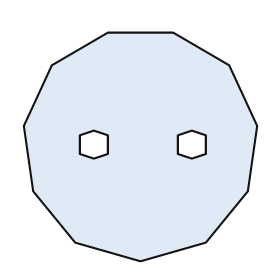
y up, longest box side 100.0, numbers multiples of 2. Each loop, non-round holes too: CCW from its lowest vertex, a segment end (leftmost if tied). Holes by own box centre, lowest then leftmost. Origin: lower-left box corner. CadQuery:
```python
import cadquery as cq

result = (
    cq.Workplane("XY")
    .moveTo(50.0, 0.0)
    .lineTo(78.0, 8.0)
    .lineTo(96.0, 30.0)
    .lineTo(100.0, 58.0)
    .lineTo(88.0, 84.0)
    .lineTo(64.0, 98.0)
    .lineTo(36.0, 98.0)
    .lineTo(12.0, 84.0)
    .lineTo(0.0, 58.0)
    .lineTo(4.0, 30.0)
    .lineTo(22.0, 8.0)
    .close()
    .moveTo(30.0, 44.0)
    .lineTo(36.0, 46.0)
    .lineTo(36.0, 54.0)
    .lineTo(30.0, 56.0)
    .lineTo(24.0, 54.0)
    .lineTo(24.0, 46.0)
    .close()
    .moveTo(72.0, 44.0)
    .lineTo(78.0, 46.0)
    .lineTo(78.0, 54.0)
    .lineTo(72.0, 56.0)
    .lineTo(66.0, 54.0)
    .lineTo(66.0, 46.0)
    .close()
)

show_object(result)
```